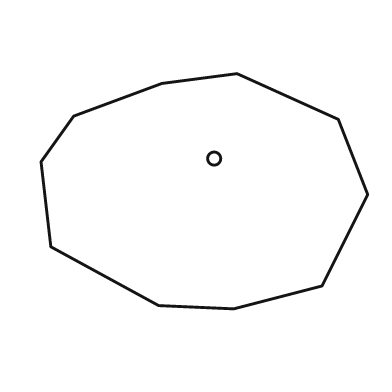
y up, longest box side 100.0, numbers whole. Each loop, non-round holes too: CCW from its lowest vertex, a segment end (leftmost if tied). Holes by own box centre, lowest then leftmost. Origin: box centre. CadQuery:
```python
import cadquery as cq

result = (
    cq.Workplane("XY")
    .moveTo(9.0, -36.0)
    .lineTo(36.0, -29.0)
    .lineTo(50.0, -1.0)
    .lineTo(41.0, 22.0)
    .lineTo(10.0, 36.0)
    .lineTo(-13.0, 33.0)
    .lineTo(-40.0, 23.0)
    .lineTo(-50.0, 9.0)
    .lineTo(-47.0, -17.0)
    .lineTo(-14.0, -35.0)
    .close()
    .moveTo(3.0, 10.0)
    .circle(2.0)
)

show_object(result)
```